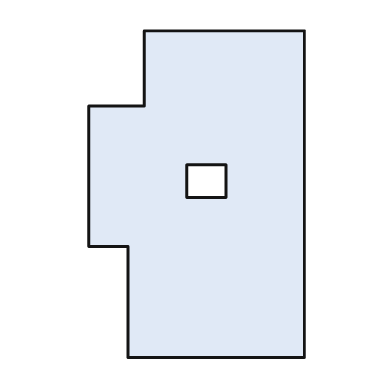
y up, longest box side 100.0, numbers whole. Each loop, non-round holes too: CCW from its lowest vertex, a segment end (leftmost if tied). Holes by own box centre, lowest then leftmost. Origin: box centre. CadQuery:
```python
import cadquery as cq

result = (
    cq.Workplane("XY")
    .moveTo(-21.0, -50.0)
    .lineTo(33.0, -50.0)
    .lineTo(33.0, 50.0)
    .lineTo(-16.0, 50.0)
    .lineTo(-16.0, 27.0)
    .lineTo(-33.0, 27.0)
    .lineTo(-33.0, -16.0)
    .lineTo(-21.0, -16.0)
    .close()
    .moveTo(-3.0, -1.0)
    .lineTo(9.0, -1.0)
    .lineTo(9.0, 9.0)
    .lineTo(-3.0, 9.0)
    .close()
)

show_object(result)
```